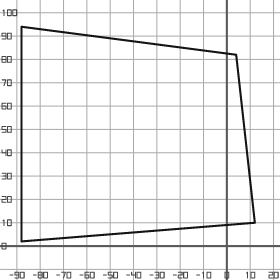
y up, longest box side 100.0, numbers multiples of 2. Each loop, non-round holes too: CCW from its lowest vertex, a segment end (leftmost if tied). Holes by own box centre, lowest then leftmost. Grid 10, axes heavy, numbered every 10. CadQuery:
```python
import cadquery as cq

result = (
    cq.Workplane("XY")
    .moveTo(-88.0, 2.0)
    .lineTo(12.0, 10.0)
    .lineTo(4.0, 82.0)
    .lineTo(-88.0, 94.0)
    .close()
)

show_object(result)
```